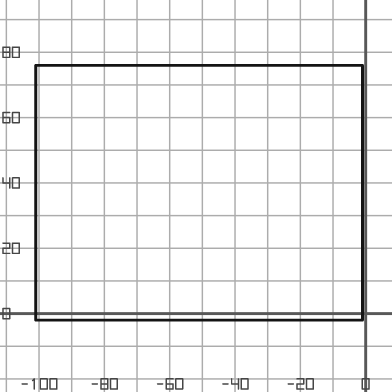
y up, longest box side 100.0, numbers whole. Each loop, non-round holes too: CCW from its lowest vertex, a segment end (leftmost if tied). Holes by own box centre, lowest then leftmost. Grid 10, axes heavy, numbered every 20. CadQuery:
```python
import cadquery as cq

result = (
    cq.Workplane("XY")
    .moveTo(-101.0, -2.0)
    .lineTo(-1.0, -2.0)
    .lineTo(-1.0, 76.0)
    .lineTo(-101.0, 76.0)
    .close()
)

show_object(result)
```